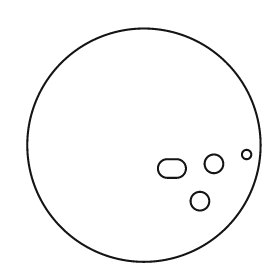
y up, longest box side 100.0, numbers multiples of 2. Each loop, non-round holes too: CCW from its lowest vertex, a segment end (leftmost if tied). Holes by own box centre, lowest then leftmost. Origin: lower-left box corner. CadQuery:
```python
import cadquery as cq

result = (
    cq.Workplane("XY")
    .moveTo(50.0, 50.0)
    .circle(50.0)
    .moveTo(74.0, 26.0)
    .circle(4.0)
    .moveTo(60.0, 36.0)
    .lineTo(64.0, 36.0)
    .threePointArc((68.0, 40.0), (64.0, 44.0))
    .lineTo(60.0, 44.0)
    .threePointArc((56.0, 40.0), (60.0, 36.0))
    .close()
    .moveTo(80.0, 42.0)
    .circle(4.0)
    .moveTo(94.0, 46.0)
    .circle(2.0)
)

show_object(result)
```